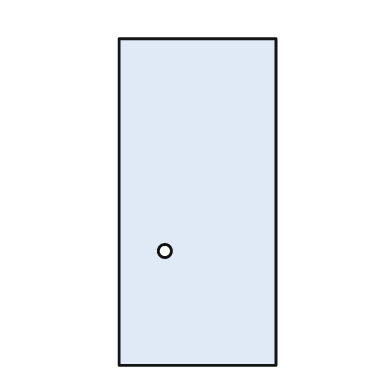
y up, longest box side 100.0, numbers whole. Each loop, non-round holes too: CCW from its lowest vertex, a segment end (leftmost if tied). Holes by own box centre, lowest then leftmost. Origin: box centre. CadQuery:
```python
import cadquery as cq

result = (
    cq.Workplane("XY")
    .moveTo(-24.0, -50.0)
    .lineTo(24.0, -50.0)
    .lineTo(24.0, 50.0)
    .lineTo(-24.0, 50.0)
    .close()
    .moveTo(-10.0, -15.0)
    .circle(2.0)
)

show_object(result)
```